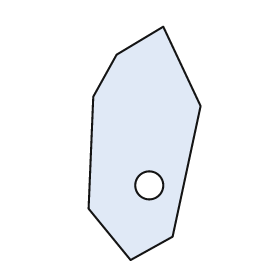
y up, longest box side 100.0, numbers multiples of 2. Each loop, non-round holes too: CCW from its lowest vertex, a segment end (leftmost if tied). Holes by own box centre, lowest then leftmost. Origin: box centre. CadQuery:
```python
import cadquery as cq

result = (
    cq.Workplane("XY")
    .moveTo(-6.0, -50.0)
    .lineTo(12.0, -40.0)
    .lineTo(24.0, 16.0)
    .lineTo(8.0, 50.0)
    .lineTo(-12.0, 38.0)
    .lineTo(-22.0, 20.0)
    .lineTo(-24.0, -28.0)
    .close()
    .moveTo(2.0, -18.0)
    .circle(6.0)
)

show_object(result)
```